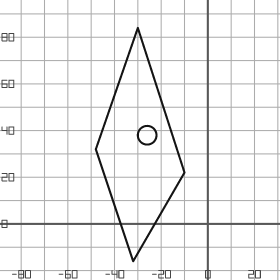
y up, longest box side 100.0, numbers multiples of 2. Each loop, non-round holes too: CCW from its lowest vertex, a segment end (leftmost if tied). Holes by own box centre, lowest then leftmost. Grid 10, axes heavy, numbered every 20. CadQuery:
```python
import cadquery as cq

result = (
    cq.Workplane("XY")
    .moveTo(-32.0, -16.0)
    .lineTo(-10.0, 22.0)
    .lineTo(-30.0, 84.0)
    .lineTo(-48.0, 32.0)
    .close()
    .moveTo(-26.0, 38.0)
    .circle(4.0)
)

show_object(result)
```